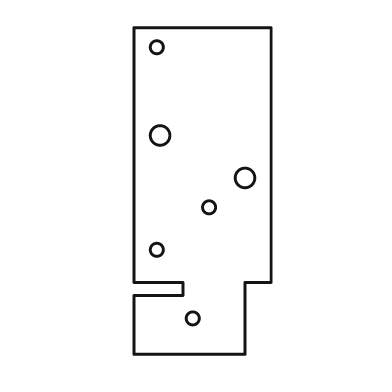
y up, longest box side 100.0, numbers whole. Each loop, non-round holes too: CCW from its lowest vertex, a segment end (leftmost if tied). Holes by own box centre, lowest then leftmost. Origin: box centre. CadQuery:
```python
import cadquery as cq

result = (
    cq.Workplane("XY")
    .moveTo(-21.0, -50.0)
    .lineTo(13.0, -50.0)
    .lineTo(13.0, -28.0)
    .lineTo(21.0, -28.0)
    .lineTo(21.0, 50.0)
    .lineTo(-21.0, 50.0)
    .lineTo(-21.0, -28.0)
    .lineTo(-6.0, -28.0)
    .lineTo(-6.0, -32.0)
    .lineTo(-21.0, -32.0)
    .close()
    .moveTo(-3.0, -39.0)
    .circle(2.0)
    .moveTo(-14.0, -18.0)
    .circle(2.0)
    .moveTo(2.0, -5.0)
    .circle(2.0)
    .moveTo(13.0, 4.0)
    .circle(3.0)
    .moveTo(-13.0, 17.0)
    .circle(3.0)
    .moveTo(-14.0, 44.0)
    .circle(2.0)
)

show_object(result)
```